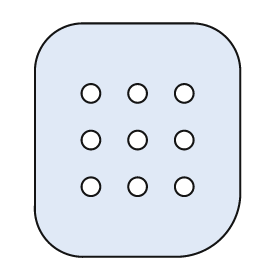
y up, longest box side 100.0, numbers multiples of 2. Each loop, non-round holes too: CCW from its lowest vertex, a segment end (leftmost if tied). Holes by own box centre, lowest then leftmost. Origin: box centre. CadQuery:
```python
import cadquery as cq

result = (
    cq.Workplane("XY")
    .moveTo(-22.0, -50.0)
    .lineTo(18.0, -50.0)
    .threePointArc((36.0, -42.0), (44.0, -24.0))
    .lineTo(44.0, 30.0)
    .threePointArc((38.0, 44.0), (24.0, 50.0))
    .lineTo(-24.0, 50.0)
    .threePointArc((-38.0, 44.0), (-44.0, 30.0))
    .lineTo(-44.0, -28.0)
    .threePointArc((-38.0, -44.0), (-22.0, -50.0))
    .close()
    .moveTo(-20.0, -20.0)
    .circle(4.0)
    .moveTo(0.0, -20.0)
    .circle(4.0)
    .moveTo(20.0, -20.0)
    .circle(4.0)
    .moveTo(-20.0, 0.0)
    .circle(4.0)
    .moveTo(0.0, 0.0)
    .circle(4.0)
    .moveTo(20.0, 0.0)
    .circle(4.0)
    .moveTo(-20.0, 20.0)
    .circle(4.0)
    .moveTo(0.0, 20.0)
    .circle(4.0)
    .moveTo(20.0, 20.0)
    .circle(4.0)
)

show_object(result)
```